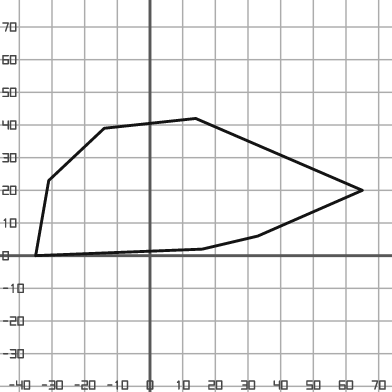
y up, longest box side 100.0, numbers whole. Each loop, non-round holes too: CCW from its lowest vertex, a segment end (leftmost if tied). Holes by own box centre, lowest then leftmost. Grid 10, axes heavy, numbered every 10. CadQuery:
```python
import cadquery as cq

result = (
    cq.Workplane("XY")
    .moveTo(-35.0, 0.0)
    .lineTo(16.0, 2.0)
    .lineTo(33.0, 6.0)
    .lineTo(65.0, 20.0)
    .lineTo(14.0, 42.0)
    .lineTo(-14.0, 39.0)
    .lineTo(-31.0, 23.0)
    .close()
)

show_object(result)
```